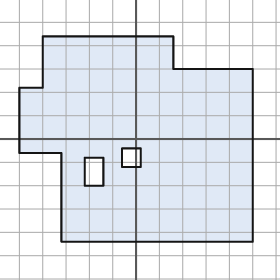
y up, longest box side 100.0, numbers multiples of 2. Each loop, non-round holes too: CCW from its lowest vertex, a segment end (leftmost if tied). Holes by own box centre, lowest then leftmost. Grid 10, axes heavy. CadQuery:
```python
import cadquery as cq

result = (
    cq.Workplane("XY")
    .moveTo(-32.0, -44.0)
    .lineTo(50.0, -44.0)
    .lineTo(50.0, 30.0)
    .lineTo(16.0, 30.0)
    .lineTo(16.0, 44.0)
    .lineTo(-40.0, 44.0)
    .lineTo(-40.0, 22.0)
    .lineTo(-50.0, 22.0)
    .lineTo(-50.0, -6.0)
    .lineTo(-32.0, -6.0)
    .close()
    .moveTo(-22.0, -20.0)
    .lineTo(-14.0, -20.0)
    .lineTo(-14.0, -8.0)
    .lineTo(-22.0, -8.0)
    .close()
    .moveTo(-6.0, -12.0)
    .lineTo(2.0, -12.0)
    .lineTo(2.0, -4.0)
    .lineTo(-6.0, -4.0)
    .close()
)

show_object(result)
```